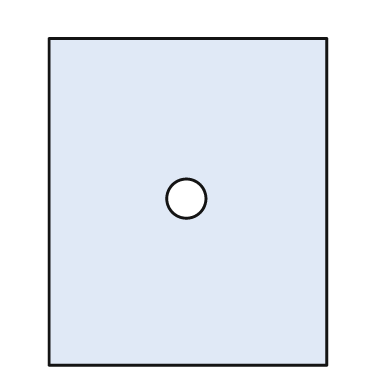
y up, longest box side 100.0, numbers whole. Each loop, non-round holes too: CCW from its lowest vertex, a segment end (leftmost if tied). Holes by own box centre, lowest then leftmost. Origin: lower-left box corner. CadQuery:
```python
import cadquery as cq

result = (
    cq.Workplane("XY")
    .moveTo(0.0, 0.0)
    .lineTo(85.0, 0.0)
    .lineTo(85.0, 100.0)
    .lineTo(0.0, 100.0)
    .close()
    .moveTo(42.0, 51.0)
    .circle(6.0)
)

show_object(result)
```